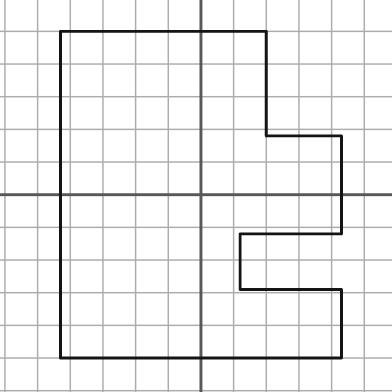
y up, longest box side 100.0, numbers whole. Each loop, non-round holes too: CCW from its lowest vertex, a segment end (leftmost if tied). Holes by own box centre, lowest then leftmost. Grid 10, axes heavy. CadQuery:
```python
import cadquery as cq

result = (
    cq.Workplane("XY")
    .moveTo(-43.0, -50.0)
    .lineTo(43.0, -50.0)
    .lineTo(43.0, -29.0)
    .lineTo(12.0, -29.0)
    .lineTo(12.0, -12.0)
    .lineTo(43.0, -12.0)
    .lineTo(43.0, 18.0)
    .lineTo(20.0, 18.0)
    .lineTo(20.0, 50.0)
    .lineTo(-43.0, 50.0)
    .close()
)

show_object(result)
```